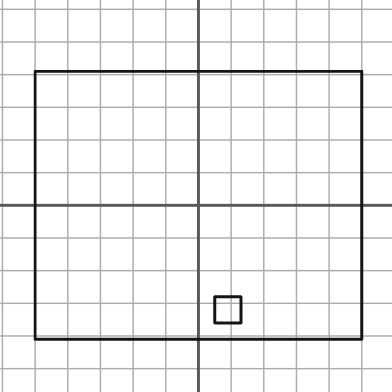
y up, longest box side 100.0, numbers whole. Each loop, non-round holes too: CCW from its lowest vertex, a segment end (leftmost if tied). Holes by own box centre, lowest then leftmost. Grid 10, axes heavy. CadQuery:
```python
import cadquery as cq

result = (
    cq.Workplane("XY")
    .moveTo(-50.0, -41.0)
    .lineTo(50.0, -41.0)
    .lineTo(50.0, 41.0)
    .lineTo(-50.0, 41.0)
    .close()
    .moveTo(5.0, -36.0)
    .lineTo(13.0, -36.0)
    .lineTo(13.0, -28.0)
    .lineTo(5.0, -28.0)
    .close()
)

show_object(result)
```